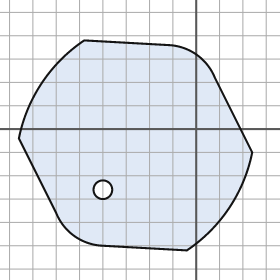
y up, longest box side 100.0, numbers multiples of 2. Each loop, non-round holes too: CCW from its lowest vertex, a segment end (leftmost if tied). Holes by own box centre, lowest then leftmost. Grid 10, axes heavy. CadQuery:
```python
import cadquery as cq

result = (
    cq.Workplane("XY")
    .moveTo(-4.0, -52.0)
    .threePointArc((14.0, -34.0), (24.0, -10.0))
    .lineTo(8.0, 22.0)
    .threePointArc((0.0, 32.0), (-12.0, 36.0))
    .lineTo(-48.0, 38.0)
    .threePointArc((-66.0, 20.0), (-76.0, -4.0))
    .lineTo(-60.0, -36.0)
    .threePointArc((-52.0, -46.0), (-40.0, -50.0))
    .close()
    .moveTo(-40.0, -26.0)
    .circle(4.0)
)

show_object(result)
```